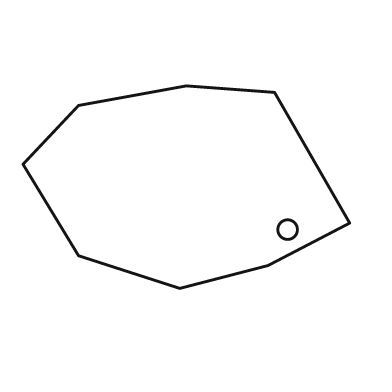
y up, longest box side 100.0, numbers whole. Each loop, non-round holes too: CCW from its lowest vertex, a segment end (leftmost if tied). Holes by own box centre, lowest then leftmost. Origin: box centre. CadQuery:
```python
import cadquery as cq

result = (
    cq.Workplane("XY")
    .moveTo(-2.0, -31.0)
    .lineTo(25.0, -24.0)
    .lineTo(50.0, -11.0)
    .lineTo(27.0, 29.0)
    .lineTo(0.0, 31.0)
    .lineTo(-33.0, 25.0)
    .lineTo(-50.0, 7.0)
    .lineTo(-33.0, -21.0)
    .close()
    .moveTo(31.0, -13.0)
    .circle(3.0)
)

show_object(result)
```